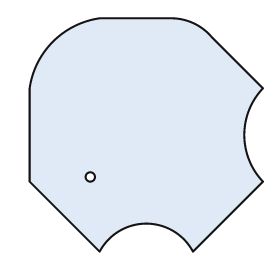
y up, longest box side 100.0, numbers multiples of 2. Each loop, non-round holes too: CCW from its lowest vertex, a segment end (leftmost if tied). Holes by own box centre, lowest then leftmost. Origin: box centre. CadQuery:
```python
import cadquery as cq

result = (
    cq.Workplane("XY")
    .moveTo(-20.0, -50.0)
    .threePointArc((0.0, -38.0), (20.0, -50.0))
    .lineTo(50.0, -20.0)
    .threePointArc((42.0, 0.0), (50.0, 20.0))
    .lineTo(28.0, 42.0)
    .threePointArc((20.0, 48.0), (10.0, 50.0))
    .lineTo(-20.0, 50.0)
    .threePointArc((-40.0, 40.0), (-50.0, 20.0))
    .lineTo(-50.0, -20.0)
    .close()
    .moveTo(-24.0, -18.0)
    .circle(2.0)
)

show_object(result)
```